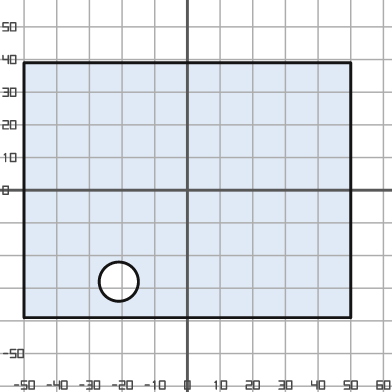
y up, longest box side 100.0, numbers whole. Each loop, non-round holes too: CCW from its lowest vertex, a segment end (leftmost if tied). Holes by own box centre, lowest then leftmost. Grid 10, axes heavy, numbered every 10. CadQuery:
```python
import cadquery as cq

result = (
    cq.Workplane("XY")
    .moveTo(-50.0, -39.0)
    .lineTo(50.0, -39.0)
    .lineTo(50.0, 39.0)
    .lineTo(-50.0, 39.0)
    .close()
    .moveTo(-21.0, -28.0)
    .circle(6.0)
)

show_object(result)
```